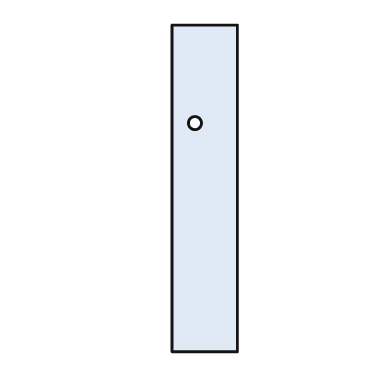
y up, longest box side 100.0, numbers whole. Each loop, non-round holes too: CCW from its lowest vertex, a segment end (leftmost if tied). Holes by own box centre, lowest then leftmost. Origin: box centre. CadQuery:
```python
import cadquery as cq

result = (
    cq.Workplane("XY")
    .moveTo(-10.0, -50.0)
    .lineTo(10.0, -50.0)
    .lineTo(10.0, 50.0)
    .lineTo(-10.0, 50.0)
    .close()
    .moveTo(-3.0, 20.0)
    .circle(2.0)
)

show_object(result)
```